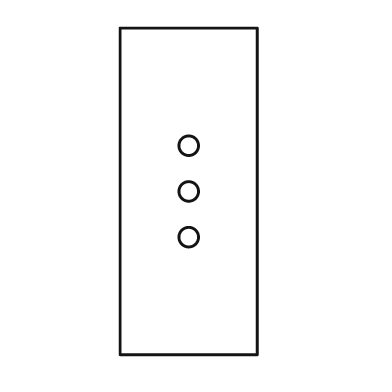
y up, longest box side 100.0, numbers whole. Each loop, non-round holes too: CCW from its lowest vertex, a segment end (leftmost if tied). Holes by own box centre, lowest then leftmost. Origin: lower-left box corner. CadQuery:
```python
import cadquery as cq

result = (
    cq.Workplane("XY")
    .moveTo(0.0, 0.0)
    .lineTo(42.0, 0.0)
    .lineTo(42.0, 100.0)
    .lineTo(0.0, 100.0)
    .close()
    .moveTo(21.0, 36.0)
    .circle(3.0)
    .moveTo(21.0, 50.0)
    .circle(3.0)
    .moveTo(21.0, 64.0)
    .circle(3.0)
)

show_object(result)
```